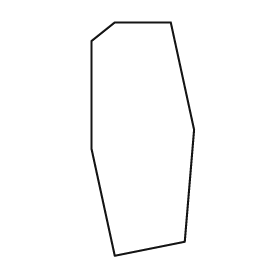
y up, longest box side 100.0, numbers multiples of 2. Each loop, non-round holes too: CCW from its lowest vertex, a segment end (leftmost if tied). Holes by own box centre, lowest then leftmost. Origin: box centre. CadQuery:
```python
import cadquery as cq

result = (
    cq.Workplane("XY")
    .moveTo(-12.0, -50.0)
    .lineTo(18.0, -44.0)
    .lineTo(22.0, 4.0)
    .lineTo(12.0, 50.0)
    .lineTo(-12.0, 50.0)
    .lineTo(-22.0, 42.0)
    .lineTo(-22.0, -4.0)
    .close()
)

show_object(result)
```